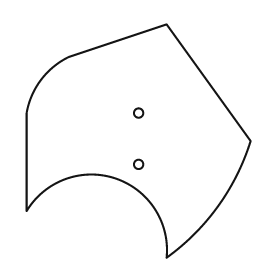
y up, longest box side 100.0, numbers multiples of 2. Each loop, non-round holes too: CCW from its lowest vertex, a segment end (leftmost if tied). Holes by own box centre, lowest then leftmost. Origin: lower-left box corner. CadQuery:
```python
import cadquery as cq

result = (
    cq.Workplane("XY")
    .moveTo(60.0, 0.0)
    .threePointArc((82.0, 22.0), (96.0, 50.0))
    .lineTo(60.0, 100.0)
    .lineTo(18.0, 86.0)
    .threePointArc((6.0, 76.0), (0.0, 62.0))
    .lineTo(0.0, 20.0)
    .threePointArc((38.0, 34.0), (60.0, 0.0))
    .close()
    .moveTo(48.0, 40.0)
    .circle(2.0)
    .moveTo(48.0, 62.0)
    .circle(2.0)
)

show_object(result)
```